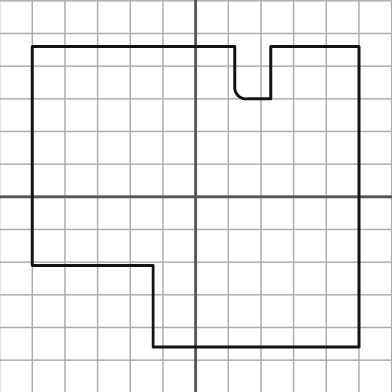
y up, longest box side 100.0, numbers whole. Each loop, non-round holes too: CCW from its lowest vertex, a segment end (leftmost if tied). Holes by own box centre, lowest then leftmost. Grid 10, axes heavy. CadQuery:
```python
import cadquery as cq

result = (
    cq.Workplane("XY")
    .moveTo(-13.0, -46.0)
    .lineTo(50.0, -46.0)
    .lineTo(50.0, 46.0)
    .lineTo(23.0, 46.0)
    .lineTo(23.0, 30.0)
    .lineTo(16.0, 30.0)
    .threePointArc((13.0, 31.0), (12.0, 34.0))
    .lineTo(12.0, 46.0)
    .lineTo(-50.0, 46.0)
    .lineTo(-50.0, -21.0)
    .lineTo(-13.0, -21.0)
    .close()
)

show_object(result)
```